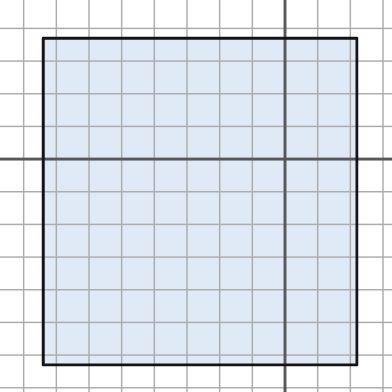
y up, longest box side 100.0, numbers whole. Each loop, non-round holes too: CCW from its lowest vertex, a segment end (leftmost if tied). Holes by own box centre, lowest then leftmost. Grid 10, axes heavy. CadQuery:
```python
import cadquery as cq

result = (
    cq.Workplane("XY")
    .moveTo(-74.0, -63.0)
    .lineTo(22.0, -63.0)
    .lineTo(22.0, 37.0)
    .lineTo(-74.0, 37.0)
    .close()
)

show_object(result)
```